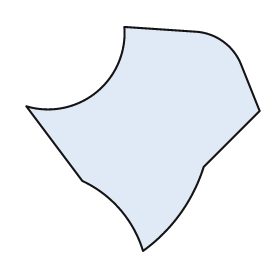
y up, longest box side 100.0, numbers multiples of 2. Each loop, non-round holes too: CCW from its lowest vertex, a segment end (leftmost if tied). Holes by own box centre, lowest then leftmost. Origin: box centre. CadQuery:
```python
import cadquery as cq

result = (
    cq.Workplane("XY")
    .moveTo(0.0, -48.0)
    .threePointArc((16.0, -32.0), (26.0, -12.0))
    .lineTo(50.0, 12.0)
    .lineTo(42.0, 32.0)
    .threePointArc((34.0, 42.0), (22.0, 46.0))
    .lineTo(-8.0, 48.0)
    .threePointArc((-20.0, 20.0), (-50.0, 14.0))
    .lineTo(-26.0, -18.0)
    .threePointArc((-10.0, -30.0), (0.0, -48.0))
    .close()
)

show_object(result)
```